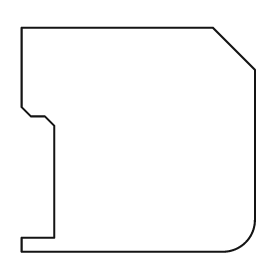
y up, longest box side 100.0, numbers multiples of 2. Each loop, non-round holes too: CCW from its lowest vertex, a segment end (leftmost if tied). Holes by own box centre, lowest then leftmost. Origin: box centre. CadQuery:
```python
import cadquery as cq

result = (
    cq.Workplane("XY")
    .moveTo(-50.0, -48.0)
    .lineTo(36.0, -48.0)
    .threePointArc((46.0, -44.0), (50.0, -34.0))
    .lineTo(50.0, 30.0)
    .lineTo(32.0, 48.0)
    .lineTo(-50.0, 48.0)
    .lineTo(-50.0, 14.0)
    .lineTo(-46.0, 10.0)
    .lineTo(-40.0, 10.0)
    .lineTo(-36.0, 6.0)
    .lineTo(-36.0, -42.0)
    .lineTo(-50.0, -42.0)
    .close()
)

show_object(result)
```